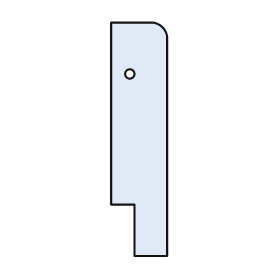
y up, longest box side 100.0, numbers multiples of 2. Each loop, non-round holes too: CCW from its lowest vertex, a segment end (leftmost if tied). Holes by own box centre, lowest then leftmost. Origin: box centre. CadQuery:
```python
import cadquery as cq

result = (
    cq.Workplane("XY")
    .moveTo(-2.0, -50.0)
    .lineTo(12.0, -50.0)
    .lineTo(12.0, 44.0)
    .threePointArc((10.0, 48.0), (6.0, 50.0))
    .lineTo(-12.0, 50.0)
    .lineTo(-12.0, -28.0)
    .lineTo(-2.0, -28.0)
    .close()
    .moveTo(-4.0, 28.0)
    .circle(2.0)
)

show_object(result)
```